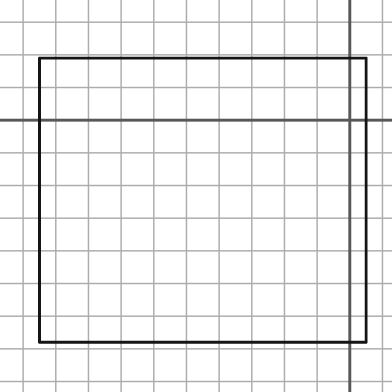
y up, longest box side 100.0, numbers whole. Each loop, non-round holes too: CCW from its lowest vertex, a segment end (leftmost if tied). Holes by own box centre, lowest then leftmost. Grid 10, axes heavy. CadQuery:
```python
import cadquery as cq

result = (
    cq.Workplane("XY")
    .moveTo(-95.0, -68.0)
    .lineTo(5.0, -68.0)
    .lineTo(5.0, 19.0)
    .lineTo(-95.0, 19.0)
    .close()
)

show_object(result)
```